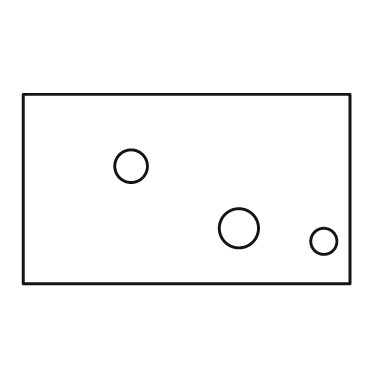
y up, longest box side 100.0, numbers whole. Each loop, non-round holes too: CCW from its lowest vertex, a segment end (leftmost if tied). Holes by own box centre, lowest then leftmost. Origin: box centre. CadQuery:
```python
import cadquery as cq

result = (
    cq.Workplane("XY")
    .moveTo(-50.0, -29.0)
    .lineTo(50.0, -29.0)
    .lineTo(50.0, 29.0)
    .lineTo(-50.0, 29.0)
    .close()
    .moveTo(42.0, -16.0)
    .circle(4.0)
    .moveTo(16.0, -12.0)
    .circle(6.0)
    .moveTo(-17.0, 7.0)
    .circle(5.0)
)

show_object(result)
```